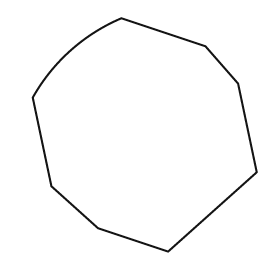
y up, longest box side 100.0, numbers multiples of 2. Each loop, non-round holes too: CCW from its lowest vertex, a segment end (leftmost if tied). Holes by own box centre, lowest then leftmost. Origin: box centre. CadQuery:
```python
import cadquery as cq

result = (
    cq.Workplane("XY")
    .moveTo(10.0, -50.0)
    .lineTo(48.0, -16.0)
    .lineTo(40.0, 22.0)
    .lineTo(26.0, 38.0)
    .lineTo(-10.0, 50.0)
    .threePointArc((-32.0, 36.0), (-48.0, 16.0))
    .lineTo(-40.0, -22.0)
    .lineTo(-20.0, -40.0)
    .close()
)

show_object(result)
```